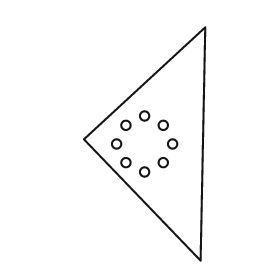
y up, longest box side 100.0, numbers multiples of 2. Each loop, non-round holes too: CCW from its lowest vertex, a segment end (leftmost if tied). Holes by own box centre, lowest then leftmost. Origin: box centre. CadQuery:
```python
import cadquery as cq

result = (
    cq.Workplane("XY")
    .moveTo(24.0, -50.0)
    .lineTo(26.0, 50.0)
    .lineTo(-26.0, 2.0)
    .close()
    .moveTo(0.0, -12.0)
    .circle(2.0)
    .moveTo(-8.0, -8.0)
    .circle(2.0)
    .moveTo(8.0, -8.0)
    .circle(2.0)
    .moveTo(-12.0, 0.0)
    .circle(2.0)
    .moveTo(12.0, 0.0)
    .circle(2.0)
    .moveTo(-8.0, 8.0)
    .circle(2.0)
    .moveTo(8.0, 8.0)
    .circle(2.0)
    .moveTo(0.0, 12.0)
    .circle(2.0)
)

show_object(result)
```